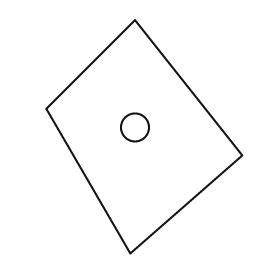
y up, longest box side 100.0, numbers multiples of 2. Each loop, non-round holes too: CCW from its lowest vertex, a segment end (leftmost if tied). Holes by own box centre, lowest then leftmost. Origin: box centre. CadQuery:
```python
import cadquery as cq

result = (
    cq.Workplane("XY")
    .moveTo(-6.0, -50.0)
    .lineTo(42.0, -8.0)
    .lineTo(-4.0, 50.0)
    .lineTo(-42.0, 12.0)
    .close()
    .moveTo(-4.0, 4.0)
    .circle(6.0)
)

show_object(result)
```